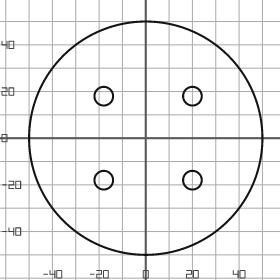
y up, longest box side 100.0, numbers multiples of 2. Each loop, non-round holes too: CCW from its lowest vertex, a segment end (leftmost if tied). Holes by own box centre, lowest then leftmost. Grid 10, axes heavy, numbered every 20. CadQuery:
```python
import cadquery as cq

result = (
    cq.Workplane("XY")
    .moveTo(0.0, 0.0)
    .circle(50.0)
    .moveTo(-18.0, -18.0)
    .circle(4.0)
    .moveTo(20.0, -18.0)
    .circle(4.0)
    .moveTo(-18.0, 18.0)
    .circle(4.0)
    .moveTo(20.0, 18.0)
    .circle(4.0)
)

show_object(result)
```